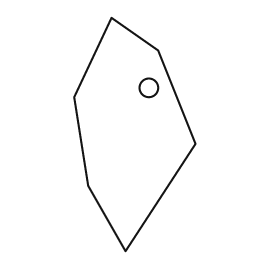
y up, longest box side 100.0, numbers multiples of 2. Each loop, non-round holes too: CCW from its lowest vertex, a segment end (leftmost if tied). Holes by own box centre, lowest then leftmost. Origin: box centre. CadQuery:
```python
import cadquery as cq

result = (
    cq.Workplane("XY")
    .moveTo(-4.0, -50.0)
    .lineTo(26.0, -4.0)
    .lineTo(10.0, 36.0)
    .lineTo(-10.0, 50.0)
    .lineTo(-26.0, 16.0)
    .lineTo(-20.0, -22.0)
    .close()
    .moveTo(6.0, 20.0)
    .circle(4.0)
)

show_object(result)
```